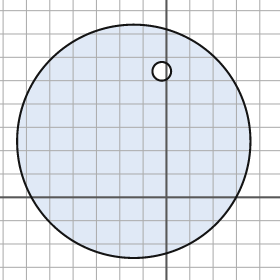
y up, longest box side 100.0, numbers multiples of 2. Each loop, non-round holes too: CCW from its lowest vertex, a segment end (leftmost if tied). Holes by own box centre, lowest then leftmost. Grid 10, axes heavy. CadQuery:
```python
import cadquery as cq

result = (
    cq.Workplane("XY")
    .moveTo(-14.0, 24.0)
    .circle(50.0)
    .moveTo(-2.0, 54.0)
    .circle(4.0)
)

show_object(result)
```